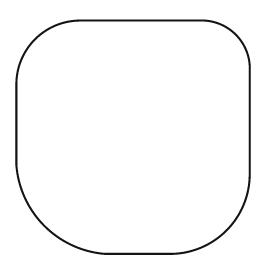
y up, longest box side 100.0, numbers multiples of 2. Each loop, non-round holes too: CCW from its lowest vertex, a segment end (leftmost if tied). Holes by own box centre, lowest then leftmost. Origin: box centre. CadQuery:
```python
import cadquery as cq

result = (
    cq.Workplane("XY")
    .moveTo(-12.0, -50.0)
    .lineTo(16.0, -50.0)
    .threePointArc((40.0, -40.0), (50.0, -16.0))
    .lineTo(50.0, 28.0)
    .threePointArc((44.0, 44.0), (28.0, 50.0))
    .lineTo(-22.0, 50.0)
    .threePointArc((-42.0, 42.0), (-50.0, 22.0))
    .lineTo(-50.0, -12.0)
    .threePointArc((-38.0, -38.0), (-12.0, -50.0))
    .close()
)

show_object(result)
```